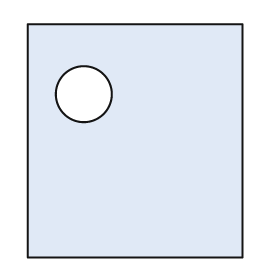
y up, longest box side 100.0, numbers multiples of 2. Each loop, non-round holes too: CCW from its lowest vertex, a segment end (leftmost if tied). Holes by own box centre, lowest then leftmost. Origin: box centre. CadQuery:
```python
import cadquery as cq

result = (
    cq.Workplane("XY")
    .moveTo(-46.0, -50.0)
    .lineTo(46.0, -50.0)
    .lineTo(46.0, 50.0)
    .lineTo(-46.0, 50.0)
    .close()
    .moveTo(-22.0, 20.0)
    .circle(12.0)
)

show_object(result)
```